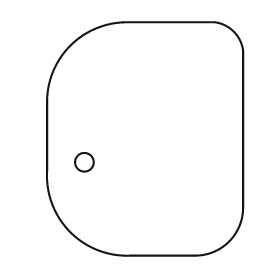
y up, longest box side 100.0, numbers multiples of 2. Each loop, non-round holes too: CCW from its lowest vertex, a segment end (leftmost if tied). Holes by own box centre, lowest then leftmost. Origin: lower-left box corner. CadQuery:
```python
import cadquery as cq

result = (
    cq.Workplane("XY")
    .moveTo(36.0, 0.0)
    .lineTo(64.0, 0.0)
    .threePointArc((78.0, 6.0), (84.0, 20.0))
    .lineTo(84.0, 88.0)
    .threePointArc((80.0, 96.0), (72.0, 100.0))
    .lineTo(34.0, 100.0)
    .threePointArc((10.0, 90.0), (0.0, 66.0))
    .lineTo(0.0, 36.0)
    .threePointArc((10.0, 10.0), (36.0, 0.0))
    .close()
    .moveTo(16.0, 40.0)
    .circle(4.0)
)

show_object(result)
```